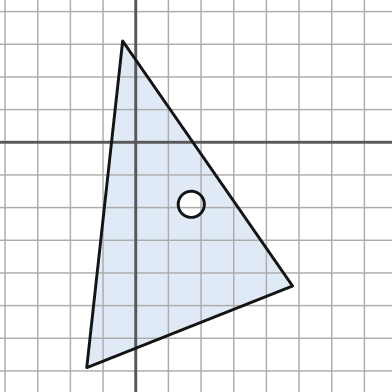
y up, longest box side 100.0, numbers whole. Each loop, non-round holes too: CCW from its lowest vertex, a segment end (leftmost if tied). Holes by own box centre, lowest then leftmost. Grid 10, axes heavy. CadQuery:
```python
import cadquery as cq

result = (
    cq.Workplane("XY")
    .moveTo(-15.0, -69.0)
    .lineTo(48.0, -44.0)
    .lineTo(-4.0, 31.0)
    .close()
    .moveTo(17.0, -19.0)
    .circle(4.0)
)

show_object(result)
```